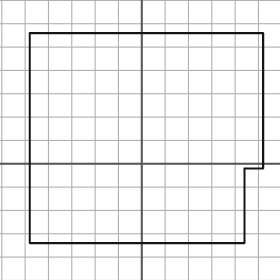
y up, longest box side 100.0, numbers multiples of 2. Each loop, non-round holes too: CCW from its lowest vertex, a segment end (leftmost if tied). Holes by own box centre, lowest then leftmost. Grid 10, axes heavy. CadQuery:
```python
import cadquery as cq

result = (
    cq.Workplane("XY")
    .moveTo(-48.0, -34.0)
    .lineTo(44.0, -34.0)
    .lineTo(44.0, -2.0)
    .lineTo(52.0, -2.0)
    .lineTo(52.0, 56.0)
    .lineTo(-48.0, 56.0)
    .close()
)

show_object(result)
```